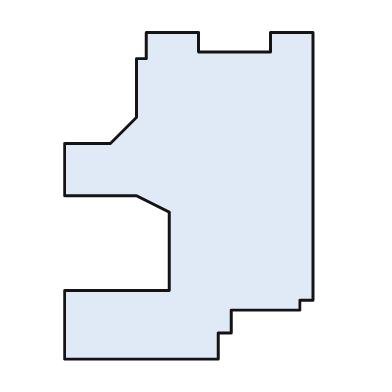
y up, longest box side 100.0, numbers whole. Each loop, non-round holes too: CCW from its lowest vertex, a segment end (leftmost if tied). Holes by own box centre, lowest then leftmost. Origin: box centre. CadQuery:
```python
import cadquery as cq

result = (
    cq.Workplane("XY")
    .moveTo(-38.0, -50.0)
    .lineTo(9.0, -50.0)
    .lineTo(9.0, -42.0)
    .lineTo(13.0, -42.0)
    .lineTo(13.0, -35.0)
    .lineTo(34.0, -35.0)
    .lineTo(34.0, -32.0)
    .lineTo(38.0, -32.0)
    .lineTo(38.0, 50.0)
    .lineTo(25.0, 50.0)
    .lineTo(25.0, 44.0)
    .lineTo(3.0, 44.0)
    .lineTo(3.0, 50.0)
    .lineTo(-13.0, 50.0)
    .lineTo(-13.0, 42.0)
    .lineTo(-16.0, 42.0)
    .lineTo(-16.0, 24.0)
    .lineTo(-24.0, 16.0)
    .lineTo(-38.0, 16.0)
    .lineTo(-38.0, 0.0)
    .lineTo(-16.0, 0.0)
    .lineTo(-6.0, -5.0)
    .lineTo(-6.0, -29.0)
    .lineTo(-38.0, -29.0)
    .close()
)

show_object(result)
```